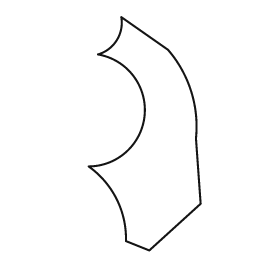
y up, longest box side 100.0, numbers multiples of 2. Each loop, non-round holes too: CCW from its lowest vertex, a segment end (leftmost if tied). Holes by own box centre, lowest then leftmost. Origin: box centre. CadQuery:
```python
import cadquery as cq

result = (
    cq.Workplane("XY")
    .moveTo(2.0, -50.0)
    .lineTo(24.0, -30.0)
    .lineTo(22.0, -2.0)
    .threePointArc((20.0, 18.0), (10.0, 36.0))
    .lineTo(-10.0, 50.0)
    .threePointArc((-12.0, 40.0), (-20.0, 34.0))
    .threePointArc((0.0, 8.0), (-24.0, -14.0))
    .threePointArc((-12.0, -28.0), (-8.0, -46.0))
    .close()
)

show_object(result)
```